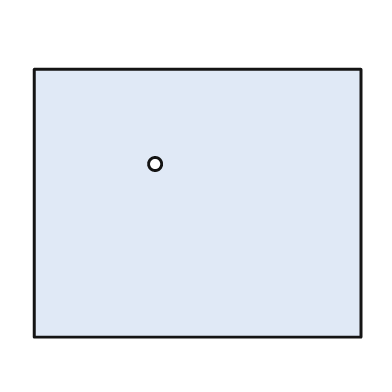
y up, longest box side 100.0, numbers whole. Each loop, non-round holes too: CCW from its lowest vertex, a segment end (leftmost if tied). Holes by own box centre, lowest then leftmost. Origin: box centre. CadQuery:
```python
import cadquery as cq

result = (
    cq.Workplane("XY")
    .moveTo(-50.0, -41.0)
    .lineTo(50.0, -41.0)
    .lineTo(50.0, 41.0)
    .lineTo(-50.0, 41.0)
    .close()
    .moveTo(-13.0, 12.0)
    .circle(2.0)
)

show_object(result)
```